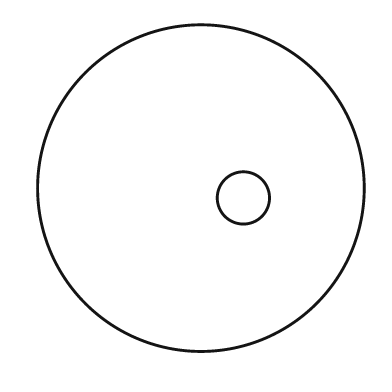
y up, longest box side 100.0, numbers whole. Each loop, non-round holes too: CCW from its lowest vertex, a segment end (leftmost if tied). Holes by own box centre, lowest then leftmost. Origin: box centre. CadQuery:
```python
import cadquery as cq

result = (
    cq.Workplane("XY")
    .moveTo(0.0, 0.0)
    .circle(50.0)
    .moveTo(13.0, -3.0)
    .circle(8.0)
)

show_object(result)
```